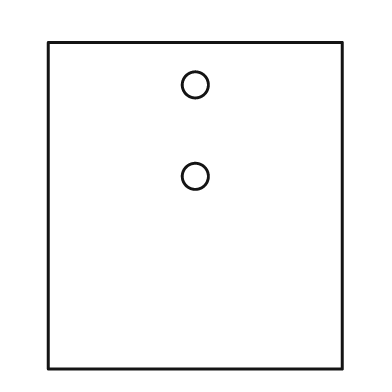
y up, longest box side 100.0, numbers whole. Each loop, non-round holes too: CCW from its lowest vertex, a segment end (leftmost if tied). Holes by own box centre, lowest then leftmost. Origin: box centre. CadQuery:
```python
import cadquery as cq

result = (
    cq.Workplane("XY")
    .moveTo(-45.0, -50.0)
    .lineTo(45.0, -50.0)
    .lineTo(45.0, 50.0)
    .lineTo(-45.0, 50.0)
    .close()
    .moveTo(0.0, 9.0)
    .circle(4.0)
    .moveTo(0.0, 37.0)
    .circle(4.0)
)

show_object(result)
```